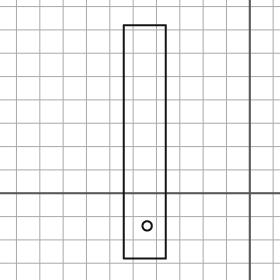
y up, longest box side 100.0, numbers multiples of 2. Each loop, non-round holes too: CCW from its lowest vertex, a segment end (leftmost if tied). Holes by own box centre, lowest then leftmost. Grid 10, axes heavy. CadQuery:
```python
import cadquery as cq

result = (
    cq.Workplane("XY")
    .moveTo(-54.0, -28.0)
    .lineTo(-36.0, -28.0)
    .lineTo(-36.0, 72.0)
    .lineTo(-54.0, 72.0)
    .close()
    .moveTo(-44.0, -14.0)
    .circle(2.0)
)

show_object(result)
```